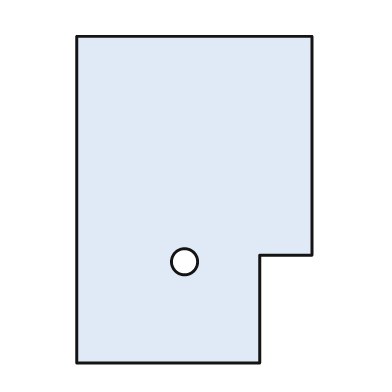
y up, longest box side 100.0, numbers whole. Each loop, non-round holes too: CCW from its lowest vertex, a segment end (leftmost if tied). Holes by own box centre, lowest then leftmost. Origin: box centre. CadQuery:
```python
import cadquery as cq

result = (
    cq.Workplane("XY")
    .moveTo(-36.0, -50.0)
    .lineTo(20.0, -50.0)
    .lineTo(20.0, -17.0)
    .lineTo(36.0, -17.0)
    .lineTo(36.0, 50.0)
    .lineTo(-36.0, 50.0)
    .close()
    .moveTo(-3.0, -19.0)
    .circle(4.0)
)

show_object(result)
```